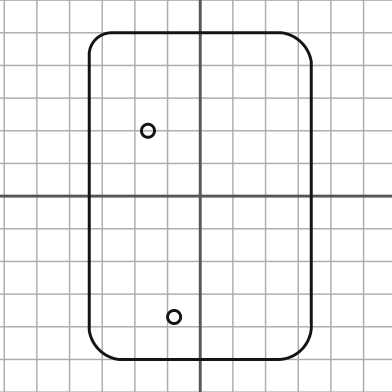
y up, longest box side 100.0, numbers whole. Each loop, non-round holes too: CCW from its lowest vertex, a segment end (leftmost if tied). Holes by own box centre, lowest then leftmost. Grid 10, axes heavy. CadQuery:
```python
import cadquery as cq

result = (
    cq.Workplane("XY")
    .moveTo(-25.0, -50.0)
    .lineTo(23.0, -50.0)
    .threePointArc((31.0, -47.0), (34.0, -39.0))
    .lineTo(34.0, 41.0)
    .threePointArc((31.0, 47.0), (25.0, 50.0))
    .lineTo(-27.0, 50.0)
    .threePointArc((-32.0, 48.0), (-34.0, 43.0))
    .lineTo(-34.0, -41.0)
    .threePointArc((-31.0, -47.0), (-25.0, -50.0))
    .close()
    .moveTo(-8.0, -37.0)
    .circle(2.0)
    .moveTo(-16.0, 20.0)
    .circle(2.0)
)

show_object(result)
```